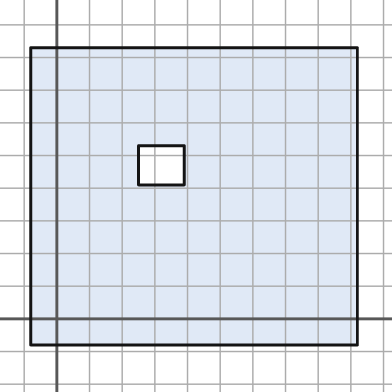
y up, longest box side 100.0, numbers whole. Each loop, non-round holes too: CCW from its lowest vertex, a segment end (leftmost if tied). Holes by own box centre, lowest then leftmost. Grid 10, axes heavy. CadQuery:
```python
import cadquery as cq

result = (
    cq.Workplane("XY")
    .moveTo(-8.0, -8.0)
    .lineTo(92.0, -8.0)
    .lineTo(92.0, 83.0)
    .lineTo(-8.0, 83.0)
    .close()
    .moveTo(25.0, 41.0)
    .lineTo(39.0, 41.0)
    .lineTo(39.0, 53.0)
    .lineTo(25.0, 53.0)
    .close()
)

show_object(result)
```